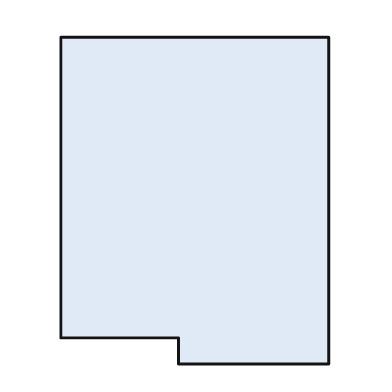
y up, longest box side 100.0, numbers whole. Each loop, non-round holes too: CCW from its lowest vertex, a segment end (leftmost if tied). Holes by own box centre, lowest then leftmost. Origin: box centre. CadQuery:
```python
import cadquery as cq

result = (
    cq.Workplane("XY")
    .moveTo(-5.0, -50.0)
    .lineTo(41.0, -50.0)
    .lineTo(41.0, 50.0)
    .lineTo(-41.0, 50.0)
    .lineTo(-41.0, -42.0)
    .lineTo(-5.0, -42.0)
    .close()
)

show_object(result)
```